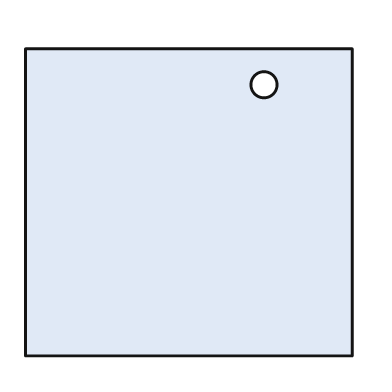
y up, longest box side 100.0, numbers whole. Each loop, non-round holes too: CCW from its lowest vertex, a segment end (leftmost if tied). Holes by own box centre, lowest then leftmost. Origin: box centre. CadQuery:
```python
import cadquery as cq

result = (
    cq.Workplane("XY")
    .moveTo(-50.0, -47.0)
    .lineTo(50.0, -47.0)
    .lineTo(50.0, 47.0)
    .lineTo(-50.0, 47.0)
    .close()
    .moveTo(23.0, 36.0)
    .circle(4.0)
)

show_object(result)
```